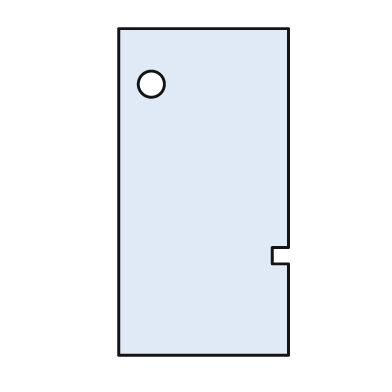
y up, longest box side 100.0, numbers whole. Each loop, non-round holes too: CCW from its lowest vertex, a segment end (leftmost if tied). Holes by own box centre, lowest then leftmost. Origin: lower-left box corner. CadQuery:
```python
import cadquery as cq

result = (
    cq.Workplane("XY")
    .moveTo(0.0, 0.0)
    .lineTo(52.0, 0.0)
    .lineTo(52.0, 28.0)
    .lineTo(47.0, 28.0)
    .lineTo(47.0, 33.0)
    .lineTo(52.0, 33.0)
    .lineTo(52.0, 100.0)
    .lineTo(0.0, 100.0)
    .close()
    .moveTo(10.0, 83.0)
    .circle(4.0)
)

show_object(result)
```